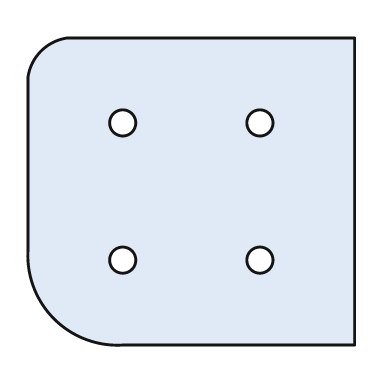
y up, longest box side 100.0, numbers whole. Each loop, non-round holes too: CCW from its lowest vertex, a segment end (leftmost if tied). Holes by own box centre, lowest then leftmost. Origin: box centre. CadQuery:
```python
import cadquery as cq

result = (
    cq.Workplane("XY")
    .moveTo(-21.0, -47.0)
    .lineTo(50.0, -47.0)
    .lineTo(50.0, 47.0)
    .lineTo(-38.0, 47.0)
    .threePointArc((-46.0, 43.0), (-50.0, 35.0))
    .lineTo(-50.0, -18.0)
    .threePointArc((-42.0, -39.0), (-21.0, -47.0))
    .close()
    .moveTo(-21.0, -21.0)
    .circle(4.0)
    .moveTo(21.0, -21.0)
    .circle(4.0)
    .moveTo(-21.0, 21.0)
    .circle(4.0)
    .moveTo(21.0, 21.0)
    .circle(4.0)
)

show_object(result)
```